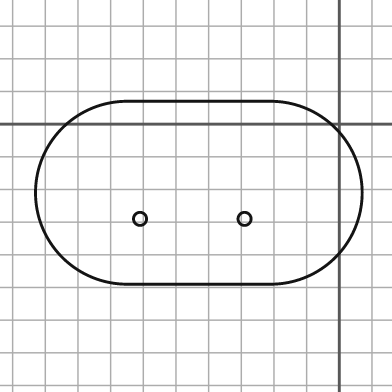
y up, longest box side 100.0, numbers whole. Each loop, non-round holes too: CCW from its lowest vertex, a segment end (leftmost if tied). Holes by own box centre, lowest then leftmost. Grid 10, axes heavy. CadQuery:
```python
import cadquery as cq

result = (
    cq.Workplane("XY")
    .moveTo(-65.0, -49.0)
    .lineTo(-21.0, -49.0)
    .threePointArc((7.0, -21.0), (-21.0, 7.0))
    .lineTo(-65.0, 7.0)
    .threePointArc((-93.0, -21.0), (-65.0, -49.0))
    .close()
    .moveTo(-61.0, -29.0)
    .circle(2.0)
    .moveTo(-29.0, -29.0)
    .circle(2.0)
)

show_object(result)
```